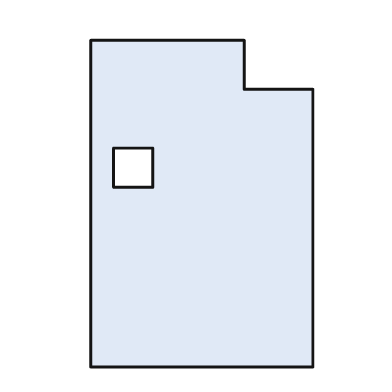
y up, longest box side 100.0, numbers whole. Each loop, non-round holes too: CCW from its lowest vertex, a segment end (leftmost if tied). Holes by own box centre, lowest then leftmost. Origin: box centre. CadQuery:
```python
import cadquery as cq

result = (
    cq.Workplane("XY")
    .moveTo(-34.0, -50.0)
    .lineTo(34.0, -50.0)
    .lineTo(34.0, 35.0)
    .lineTo(13.0, 35.0)
    .lineTo(13.0, 50.0)
    .lineTo(-34.0, 50.0)
    .close()
    .moveTo(-27.0, 5.0)
    .lineTo(-15.0, 5.0)
    .lineTo(-15.0, 17.0)
    .lineTo(-27.0, 17.0)
    .close()
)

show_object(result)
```